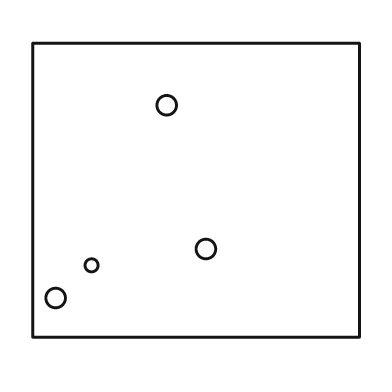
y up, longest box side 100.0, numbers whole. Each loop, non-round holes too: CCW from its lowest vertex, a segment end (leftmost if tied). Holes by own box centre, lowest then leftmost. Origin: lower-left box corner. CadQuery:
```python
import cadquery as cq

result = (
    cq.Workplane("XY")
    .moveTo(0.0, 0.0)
    .lineTo(100.0, 0.0)
    .lineTo(100.0, 90.0)
    .lineTo(0.0, 90.0)
    .close()
    .moveTo(7.0, 12.0)
    .circle(3.0)
    .moveTo(18.0, 22.0)
    .circle(2.0)
    .moveTo(53.0, 27.0)
    .circle(3.0)
    .moveTo(41.0, 71.0)
    .circle(3.0)
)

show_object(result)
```